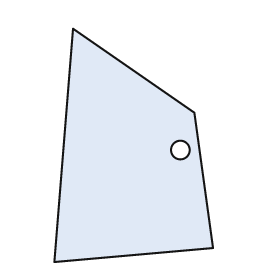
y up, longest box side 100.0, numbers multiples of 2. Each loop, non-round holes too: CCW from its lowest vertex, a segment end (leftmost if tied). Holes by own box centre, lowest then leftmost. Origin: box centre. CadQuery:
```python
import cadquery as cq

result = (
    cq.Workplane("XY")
    .moveTo(-34.0, -50.0)
    .lineTo(34.0, -44.0)
    .lineTo(26.0, 14.0)
    .lineTo(-26.0, 50.0)
    .close()
    .moveTo(20.0, -2.0)
    .circle(4.0)
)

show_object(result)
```